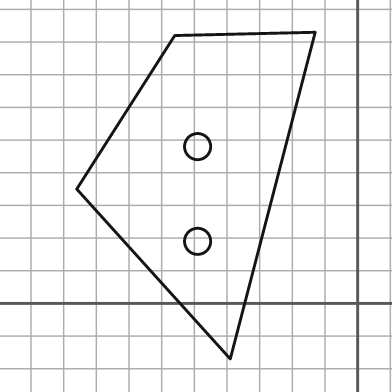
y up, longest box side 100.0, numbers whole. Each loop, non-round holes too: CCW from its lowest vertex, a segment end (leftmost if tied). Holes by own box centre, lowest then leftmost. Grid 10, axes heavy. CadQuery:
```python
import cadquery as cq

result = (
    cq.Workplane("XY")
    .moveTo(-39.0, -17.0)
    .lineTo(-13.0, 83.0)
    .lineTo(-56.0, 82.0)
    .lineTo(-86.0, 35.0)
    .close()
    .moveTo(-49.0, 19.0)
    .circle(4.0)
    .moveTo(-49.0, 48.0)
    .circle(4.0)
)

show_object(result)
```